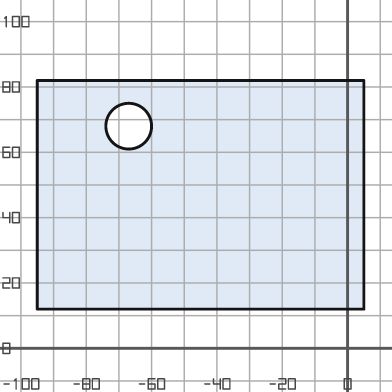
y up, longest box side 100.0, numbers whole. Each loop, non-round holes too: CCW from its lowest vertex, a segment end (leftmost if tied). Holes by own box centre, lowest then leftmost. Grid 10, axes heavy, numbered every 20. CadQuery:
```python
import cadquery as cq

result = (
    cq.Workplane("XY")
    .moveTo(-95.0, 12.0)
    .lineTo(5.0, 12.0)
    .lineTo(5.0, 82.0)
    .lineTo(-95.0, 82.0)
    .close()
    .moveTo(-67.0, 68.0)
    .circle(7.0)
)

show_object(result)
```